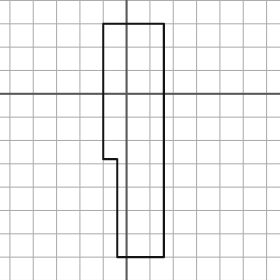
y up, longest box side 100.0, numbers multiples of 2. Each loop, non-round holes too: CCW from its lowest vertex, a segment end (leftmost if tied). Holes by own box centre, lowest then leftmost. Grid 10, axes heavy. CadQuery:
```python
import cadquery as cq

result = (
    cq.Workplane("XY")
    .moveTo(-4.0, -70.0)
    .lineTo(16.0, -70.0)
    .lineTo(16.0, 30.0)
    .lineTo(-10.0, 30.0)
    .lineTo(-10.0, -28.0)
    .lineTo(-4.0, -28.0)
    .close()
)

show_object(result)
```